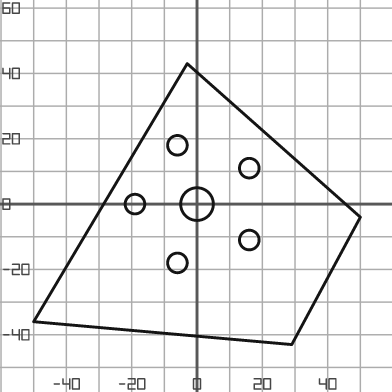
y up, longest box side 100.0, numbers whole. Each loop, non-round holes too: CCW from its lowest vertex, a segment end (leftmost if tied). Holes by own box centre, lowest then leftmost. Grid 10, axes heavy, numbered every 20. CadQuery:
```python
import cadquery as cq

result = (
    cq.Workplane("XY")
    .moveTo(29.0, -43.0)
    .lineTo(50.0, -4.0)
    .lineTo(-3.0, 43.0)
    .lineTo(-50.0, -36.0)
    .close()
    .moveTo(-6.0, -18.0)
    .circle(3.0)
    .moveTo(16.0, -11.0)
    .circle(3.0)
    .moveTo(-19.0, 0.0)
    .circle(3.0)
    .moveTo(0.0, 0.0)
    .circle(5.0)
    .moveTo(16.0, 11.0)
    .circle(3.0)
    .moveTo(-6.0, 18.0)
    .circle(3.0)
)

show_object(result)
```